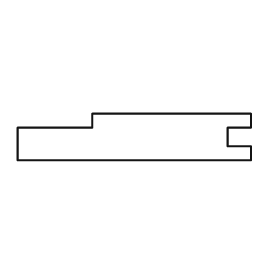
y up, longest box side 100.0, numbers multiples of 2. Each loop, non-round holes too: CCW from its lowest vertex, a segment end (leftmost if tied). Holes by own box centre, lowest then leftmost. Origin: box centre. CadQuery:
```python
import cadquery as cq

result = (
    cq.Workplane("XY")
    .moveTo(-50.0, -10.0)
    .lineTo(50.0, -10.0)
    .lineTo(50.0, -4.0)
    .lineTo(40.0, -4.0)
    .lineTo(40.0, 4.0)
    .lineTo(50.0, 4.0)
    .lineTo(50.0, 10.0)
    .lineTo(-18.0, 10.0)
    .lineTo(-18.0, 4.0)
    .lineTo(-50.0, 4.0)
    .close()
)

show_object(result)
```